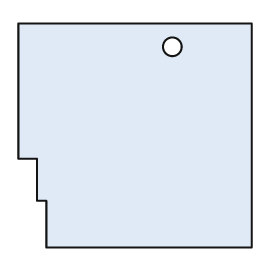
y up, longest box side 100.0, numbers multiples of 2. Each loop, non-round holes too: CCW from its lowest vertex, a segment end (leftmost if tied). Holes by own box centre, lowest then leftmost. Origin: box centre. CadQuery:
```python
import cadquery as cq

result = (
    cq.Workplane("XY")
    .moveTo(-38.0, -48.0)
    .lineTo(50.0, -48.0)
    .lineTo(50.0, 48.0)
    .lineTo(-50.0, 48.0)
    .lineTo(-50.0, -10.0)
    .lineTo(-42.0, -10.0)
    .lineTo(-42.0, -28.0)
    .lineTo(-38.0, -28.0)
    .close()
    .moveTo(16.0, 38.0)
    .circle(4.0)
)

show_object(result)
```